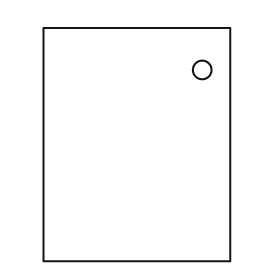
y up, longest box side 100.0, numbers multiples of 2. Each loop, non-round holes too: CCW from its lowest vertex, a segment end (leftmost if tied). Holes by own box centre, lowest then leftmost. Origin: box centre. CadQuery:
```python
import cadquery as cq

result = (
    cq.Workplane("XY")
    .moveTo(-40.0, -50.0)
    .lineTo(40.0, -50.0)
    .lineTo(40.0, 50.0)
    .lineTo(-40.0, 50.0)
    .close()
    .moveTo(28.0, 32.0)
    .circle(4.0)
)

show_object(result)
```